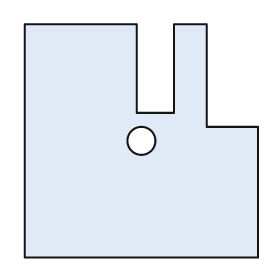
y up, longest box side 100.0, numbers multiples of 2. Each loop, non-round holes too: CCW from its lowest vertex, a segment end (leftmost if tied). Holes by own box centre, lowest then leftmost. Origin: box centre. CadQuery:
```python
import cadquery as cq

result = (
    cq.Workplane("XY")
    .moveTo(-50.0, -50.0)
    .lineTo(50.0, -50.0)
    .lineTo(50.0, 6.0)
    .lineTo(28.0, 6.0)
    .lineTo(28.0, 50.0)
    .lineTo(14.0, 50.0)
    .lineTo(14.0, 12.0)
    .lineTo(-2.0, 12.0)
    .lineTo(-2.0, 50.0)
    .lineTo(-50.0, 50.0)
    .close()
    .moveTo(0.0, 0.0)
    .circle(6.0)
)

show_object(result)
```